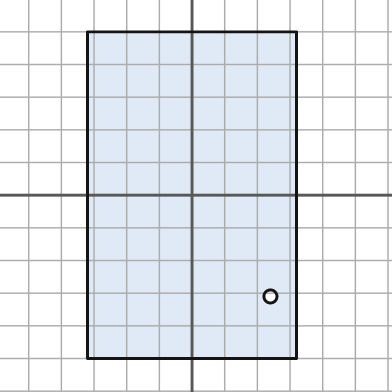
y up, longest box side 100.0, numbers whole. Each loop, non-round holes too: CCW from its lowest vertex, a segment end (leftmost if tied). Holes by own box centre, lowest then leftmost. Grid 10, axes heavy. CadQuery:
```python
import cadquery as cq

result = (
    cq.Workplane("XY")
    .moveTo(-32.0, -50.0)
    .lineTo(32.0, -50.0)
    .lineTo(32.0, 50.0)
    .lineTo(-32.0, 50.0)
    .close()
    .moveTo(24.0, -31.0)
    .circle(2.0)
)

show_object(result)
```